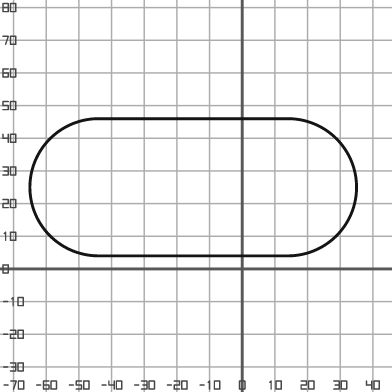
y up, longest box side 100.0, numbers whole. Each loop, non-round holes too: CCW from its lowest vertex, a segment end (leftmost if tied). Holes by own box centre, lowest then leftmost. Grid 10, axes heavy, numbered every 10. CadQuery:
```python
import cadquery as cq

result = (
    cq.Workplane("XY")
    .moveTo(-44.0, 4.0)
    .lineTo(14.0, 4.0)
    .threePointArc((35.0, 25.0), (14.0, 46.0))
    .lineTo(-44.0, 46.0)
    .threePointArc((-65.0, 25.0), (-44.0, 4.0))
    .close()
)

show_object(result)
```